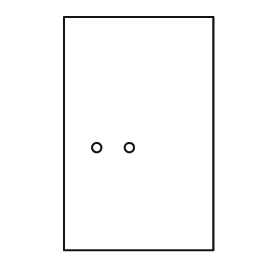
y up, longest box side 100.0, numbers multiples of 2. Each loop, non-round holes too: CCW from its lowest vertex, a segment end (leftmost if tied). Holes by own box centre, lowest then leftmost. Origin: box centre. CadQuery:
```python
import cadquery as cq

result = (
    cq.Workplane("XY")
    .moveTo(-32.0, -50.0)
    .lineTo(32.0, -50.0)
    .lineTo(32.0, 50.0)
    .lineTo(-32.0, 50.0)
    .close()
    .moveTo(-18.0, -6.0)
    .circle(2.0)
    .moveTo(-4.0, -6.0)
    .circle(2.0)
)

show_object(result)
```